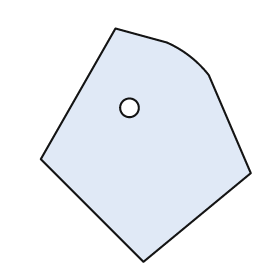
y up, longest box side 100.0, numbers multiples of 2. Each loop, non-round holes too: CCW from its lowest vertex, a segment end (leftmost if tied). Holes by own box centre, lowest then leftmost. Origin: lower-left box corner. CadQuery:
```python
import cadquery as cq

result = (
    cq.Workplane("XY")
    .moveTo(44.0, 0.0)
    .lineTo(90.0, 38.0)
    .lineTo(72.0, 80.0)
    .threePointArc((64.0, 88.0), (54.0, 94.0))
    .lineTo(32.0, 100.0)
    .lineTo(0.0, 44.0)
    .close()
    .moveTo(38.0, 66.0)
    .circle(4.0)
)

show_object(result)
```